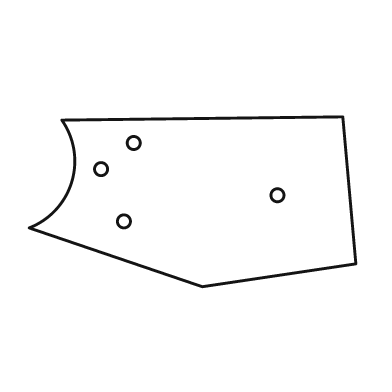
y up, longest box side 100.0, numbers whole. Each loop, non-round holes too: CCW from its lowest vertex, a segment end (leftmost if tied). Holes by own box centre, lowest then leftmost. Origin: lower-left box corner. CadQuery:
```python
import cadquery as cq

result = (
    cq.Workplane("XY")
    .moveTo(53.0, 0.0)
    .lineTo(100.0, 7.0)
    .lineTo(96.0, 52.0)
    .lineTo(10.0, 51.0)
    .threePointArc((13.0, 32.0), (0.0, 18.0))
    .close()
    .moveTo(29.0, 20.0)
    .circle(2.0)
    .moveTo(76.0, 28.0)
    .circle(2.0)
    .moveTo(22.0, 36.0)
    .circle(2.0)
    .moveTo(32.0, 44.0)
    .circle(2.0)
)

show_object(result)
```